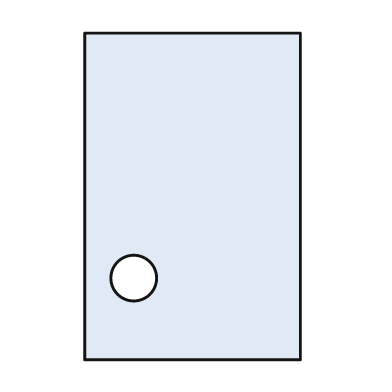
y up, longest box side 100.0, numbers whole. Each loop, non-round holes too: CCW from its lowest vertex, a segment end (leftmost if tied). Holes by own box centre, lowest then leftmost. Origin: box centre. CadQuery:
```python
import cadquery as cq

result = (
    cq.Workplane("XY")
    .moveTo(-33.0, -50.0)
    .lineTo(33.0, -50.0)
    .lineTo(33.0, 50.0)
    .lineTo(-33.0, 50.0)
    .close()
    .moveTo(-18.0, -25.0)
    .circle(7.0)
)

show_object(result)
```